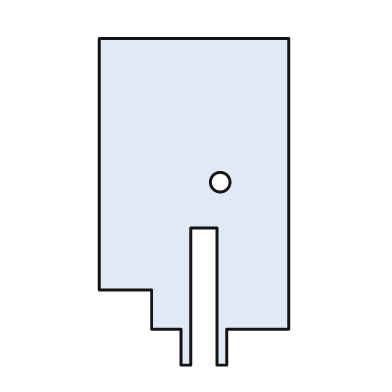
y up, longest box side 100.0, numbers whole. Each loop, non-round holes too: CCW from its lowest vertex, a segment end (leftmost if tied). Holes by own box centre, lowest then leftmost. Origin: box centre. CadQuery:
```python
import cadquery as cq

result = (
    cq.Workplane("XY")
    .moveTo(-4.0, -50.0)
    .lineTo(-1.0, -50.0)
    .lineTo(-1.0, -8.0)
    .lineTo(7.0, -8.0)
    .lineTo(7.0, -50.0)
    .lineTo(10.0, -50.0)
    .lineTo(10.0, -39.0)
    .lineTo(29.0, -39.0)
    .lineTo(29.0, 50.0)
    .lineTo(-29.0, 50.0)
    .lineTo(-29.0, -27.0)
    .lineTo(-13.0, -27.0)
    .lineTo(-13.0, -39.0)
    .lineTo(-4.0, -39.0)
    .close()
    .moveTo(8.0, 6.0)
    .circle(3.0)
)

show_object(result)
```